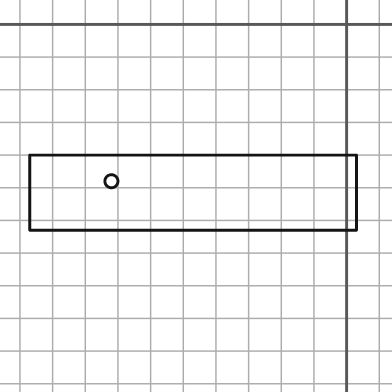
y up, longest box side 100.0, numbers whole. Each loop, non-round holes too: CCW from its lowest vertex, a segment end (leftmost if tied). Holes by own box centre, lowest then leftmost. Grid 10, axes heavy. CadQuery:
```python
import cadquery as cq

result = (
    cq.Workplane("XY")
    .moveTo(-97.0, -63.0)
    .lineTo(3.0, -63.0)
    .lineTo(3.0, -40.0)
    .lineTo(-97.0, -40.0)
    .close()
    .moveTo(-72.0, -48.0)
    .circle(2.0)
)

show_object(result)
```